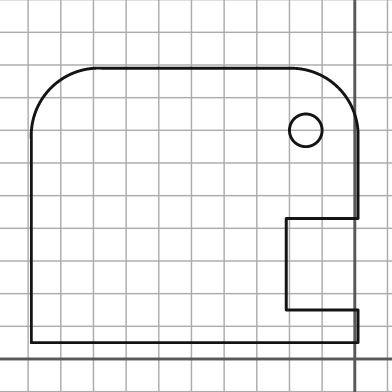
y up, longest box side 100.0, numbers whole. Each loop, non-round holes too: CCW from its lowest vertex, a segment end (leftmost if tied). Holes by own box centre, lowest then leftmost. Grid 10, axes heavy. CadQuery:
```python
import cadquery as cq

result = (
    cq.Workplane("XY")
    .moveTo(-99.0, 5.0)
    .lineTo(1.0, 5.0)
    .lineTo(1.0, 15.0)
    .lineTo(-21.0, 15.0)
    .lineTo(-21.0, 43.0)
    .lineTo(1.0, 43.0)
    .lineTo(1.0, 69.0)
    .threePointArc((-5.0, 83.0), (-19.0, 89.0))
    .lineTo(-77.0, 89.0)
    .threePointArc((-93.0, 83.0), (-99.0, 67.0))
    .close()
    .moveTo(-15.0, 70.0)
    .circle(5.0)
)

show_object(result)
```